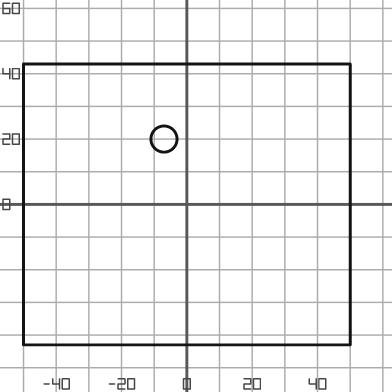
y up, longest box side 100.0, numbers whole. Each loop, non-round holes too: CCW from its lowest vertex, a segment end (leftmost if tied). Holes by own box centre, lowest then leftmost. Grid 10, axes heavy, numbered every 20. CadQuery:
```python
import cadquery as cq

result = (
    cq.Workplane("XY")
    .moveTo(-50.0, -43.0)
    .lineTo(50.0, -43.0)
    .lineTo(50.0, 43.0)
    .lineTo(-50.0, 43.0)
    .close()
    .moveTo(-7.0, 20.0)
    .circle(4.0)
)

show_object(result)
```